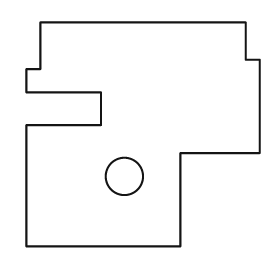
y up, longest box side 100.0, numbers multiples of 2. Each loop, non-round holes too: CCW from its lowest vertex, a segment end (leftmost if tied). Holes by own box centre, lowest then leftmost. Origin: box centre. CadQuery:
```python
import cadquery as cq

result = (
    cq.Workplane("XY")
    .moveTo(-50.0, -48.0)
    .lineTo(16.0, -48.0)
    .lineTo(16.0, -8.0)
    .lineTo(50.0, -8.0)
    .lineTo(50.0, 32.0)
    .lineTo(44.0, 32.0)
    .lineTo(44.0, 48.0)
    .lineTo(-44.0, 48.0)
    .lineTo(-44.0, 28.0)
    .lineTo(-50.0, 28.0)
    .lineTo(-50.0, 18.0)
    .lineTo(-18.0, 18.0)
    .lineTo(-18.0, 4.0)
    .lineTo(-50.0, 4.0)
    .close()
    .moveTo(-8.0, -18.0)
    .circle(8.0)
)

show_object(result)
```